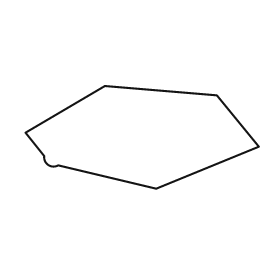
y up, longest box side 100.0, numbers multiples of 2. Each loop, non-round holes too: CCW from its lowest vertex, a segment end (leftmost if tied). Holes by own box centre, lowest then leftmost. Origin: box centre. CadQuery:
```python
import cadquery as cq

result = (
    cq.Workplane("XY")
    .moveTo(6.0, -22.0)
    .lineTo(50.0, -4.0)
    .lineTo(32.0, 18.0)
    .lineTo(-16.0, 22.0)
    .lineTo(-50.0, 2.0)
    .lineTo(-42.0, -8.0)
    .threePointArc((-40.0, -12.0), (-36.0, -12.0))
    .close()
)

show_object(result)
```